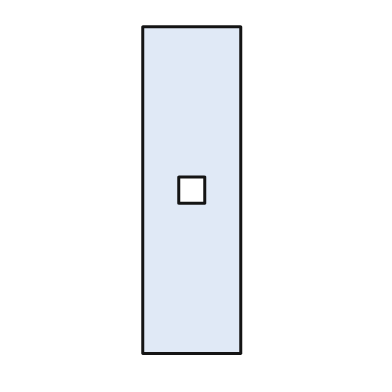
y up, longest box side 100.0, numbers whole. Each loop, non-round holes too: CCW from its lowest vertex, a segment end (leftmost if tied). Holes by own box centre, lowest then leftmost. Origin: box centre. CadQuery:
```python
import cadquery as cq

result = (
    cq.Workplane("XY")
    .moveTo(-15.0, -50.0)
    .lineTo(15.0, -50.0)
    .lineTo(15.0, 50.0)
    .lineTo(-15.0, 50.0)
    .close()
    .moveTo(-4.0, -4.0)
    .lineTo(4.0, -4.0)
    .lineTo(4.0, 4.0)
    .lineTo(-4.0, 4.0)
    .close()
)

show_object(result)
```